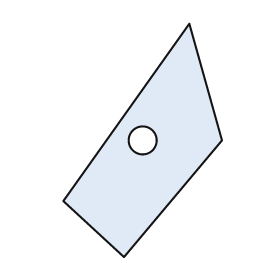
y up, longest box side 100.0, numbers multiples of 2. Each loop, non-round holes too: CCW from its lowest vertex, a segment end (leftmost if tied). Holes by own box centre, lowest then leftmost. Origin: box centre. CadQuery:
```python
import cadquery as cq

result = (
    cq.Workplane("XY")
    .moveTo(-8.0, -50.0)
    .lineTo(34.0, 0.0)
    .lineTo(20.0, 50.0)
    .lineTo(-34.0, -26.0)
    .close()
    .moveTo(0.0, 0.0)
    .circle(6.0)
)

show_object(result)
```